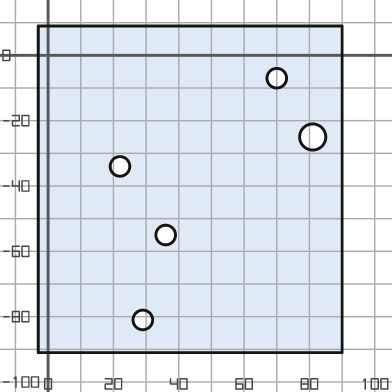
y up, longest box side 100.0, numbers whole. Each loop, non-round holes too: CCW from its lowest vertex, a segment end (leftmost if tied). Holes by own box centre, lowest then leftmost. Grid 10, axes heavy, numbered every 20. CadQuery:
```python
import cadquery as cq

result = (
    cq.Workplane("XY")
    .moveTo(-3.0, -91.0)
    .lineTo(90.0, -91.0)
    .lineTo(90.0, 9.0)
    .lineTo(-3.0, 9.0)
    .close()
    .moveTo(29.0, -81.0)
    .circle(3.0)
    .moveTo(36.0, -55.0)
    .circle(3.0)
    .moveTo(22.0, -34.0)
    .circle(3.0)
    .moveTo(81.0, -25.0)
    .circle(4.0)
    .moveTo(70.0, -7.0)
    .circle(3.0)
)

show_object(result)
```